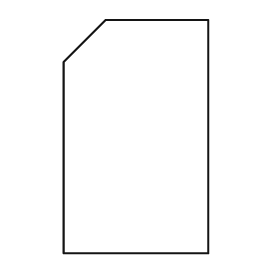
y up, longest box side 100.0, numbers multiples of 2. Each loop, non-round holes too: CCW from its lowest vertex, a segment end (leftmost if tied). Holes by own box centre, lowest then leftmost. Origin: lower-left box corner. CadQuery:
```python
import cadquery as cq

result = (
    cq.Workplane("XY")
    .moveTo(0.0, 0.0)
    .lineTo(62.0, 0.0)
    .lineTo(62.0, 100.0)
    .lineTo(18.0, 100.0)
    .lineTo(0.0, 82.0)
    .close()
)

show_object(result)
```